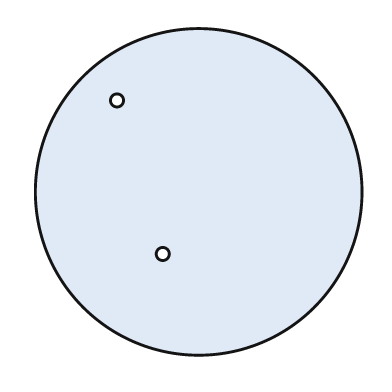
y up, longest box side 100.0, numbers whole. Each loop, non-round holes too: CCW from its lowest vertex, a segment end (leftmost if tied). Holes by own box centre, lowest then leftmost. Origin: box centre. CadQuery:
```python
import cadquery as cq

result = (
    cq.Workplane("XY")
    .moveTo(0.0, 0.0)
    .circle(50.0)
    .moveTo(-11.0, -19.0)
    .circle(2.0)
    .moveTo(-25.0, 28.0)
    .circle(2.0)
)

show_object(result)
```